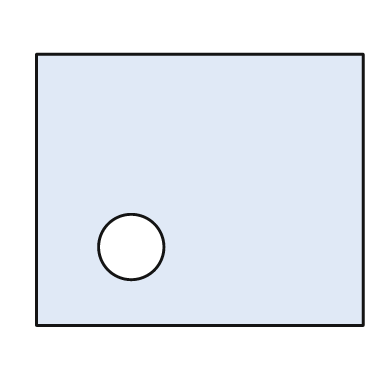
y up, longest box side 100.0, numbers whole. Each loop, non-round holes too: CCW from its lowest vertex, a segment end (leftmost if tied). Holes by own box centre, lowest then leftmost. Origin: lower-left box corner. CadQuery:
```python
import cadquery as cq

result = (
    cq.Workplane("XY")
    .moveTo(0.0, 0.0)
    .lineTo(100.0, 0.0)
    .lineTo(100.0, 83.0)
    .lineTo(0.0, 83.0)
    .close()
    .moveTo(29.0, 24.0)
    .circle(10.0)
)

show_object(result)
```